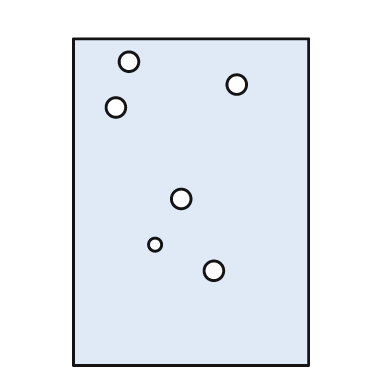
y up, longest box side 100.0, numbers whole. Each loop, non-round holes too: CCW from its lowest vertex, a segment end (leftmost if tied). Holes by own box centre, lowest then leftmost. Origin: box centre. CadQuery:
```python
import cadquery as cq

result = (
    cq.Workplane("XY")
    .moveTo(-36.0, -50.0)
    .lineTo(36.0, -50.0)
    .lineTo(36.0, 50.0)
    .lineTo(-36.0, 50.0)
    .close()
    .moveTo(7.0, -21.0)
    .circle(3.0)
    .moveTo(-11.0, -13.0)
    .circle(2.0)
    .moveTo(-3.0, 1.0)
    .circle(3.0)
    .moveTo(-23.0, 29.0)
    .circle(3.0)
    .moveTo(14.0, 36.0)
    .circle(3.0)
    .moveTo(-19.0, 43.0)
    .circle(3.0)
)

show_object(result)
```